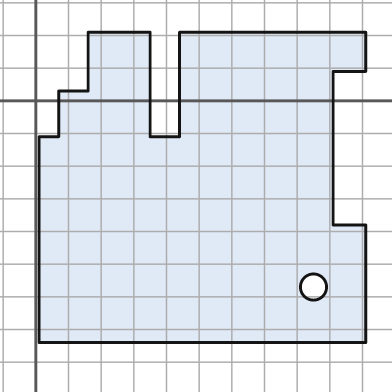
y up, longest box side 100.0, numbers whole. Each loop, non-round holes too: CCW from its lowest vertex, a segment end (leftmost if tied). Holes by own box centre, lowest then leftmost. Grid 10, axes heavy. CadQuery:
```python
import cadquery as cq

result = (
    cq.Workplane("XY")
    .moveTo(1.0, -74.0)
    .lineTo(101.0, -74.0)
    .lineTo(101.0, -38.0)
    .lineTo(91.0, -38.0)
    .lineTo(91.0, 9.0)
    .lineTo(101.0, 9.0)
    .lineTo(101.0, 21.0)
    .lineTo(44.0, 21.0)
    .lineTo(44.0, -11.0)
    .lineTo(35.0, -11.0)
    .lineTo(35.0, 21.0)
    .lineTo(16.0, 21.0)
    .lineTo(16.0, 3.0)
    .lineTo(7.0, 3.0)
    .lineTo(7.0, -11.0)
    .lineTo(1.0, -11.0)
    .close()
    .moveTo(85.0, -57.0)
    .circle(4.0)
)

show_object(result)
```